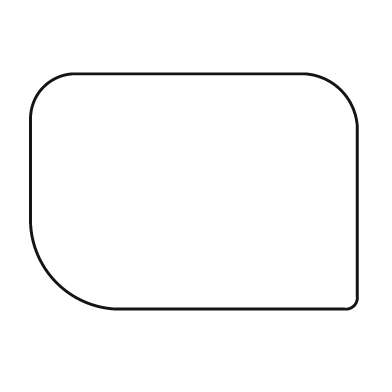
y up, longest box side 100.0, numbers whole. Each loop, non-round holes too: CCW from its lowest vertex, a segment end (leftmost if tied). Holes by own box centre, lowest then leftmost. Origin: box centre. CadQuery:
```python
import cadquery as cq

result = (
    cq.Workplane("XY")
    .moveTo(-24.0, -36.0)
    .lineTo(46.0, -36.0)
    .threePointArc((49.0, -35.0), (50.0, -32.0))
    .lineTo(50.0, 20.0)
    .threePointArc((45.0, 31.0), (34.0, 36.0))
    .lineTo(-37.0, 36.0)
    .threePointArc((-46.0, 32.0), (-50.0, 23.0))
    .lineTo(-50.0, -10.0)
    .threePointArc((-42.0, -28.0), (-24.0, -36.0))
    .close()
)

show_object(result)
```